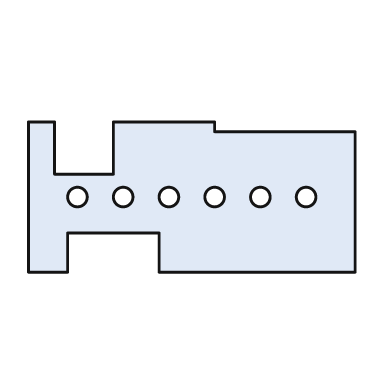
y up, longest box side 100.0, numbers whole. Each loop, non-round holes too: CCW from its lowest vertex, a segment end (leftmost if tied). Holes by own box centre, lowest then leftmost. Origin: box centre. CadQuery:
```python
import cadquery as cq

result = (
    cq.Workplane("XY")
    .moveTo(-50.0, -23.0)
    .lineTo(-38.0, -23.0)
    .lineTo(-38.0, -11.0)
    .lineTo(-10.0, -11.0)
    .lineTo(-10.0, -23.0)
    .lineTo(50.0, -23.0)
    .lineTo(50.0, 20.0)
    .lineTo(7.0, 20.0)
    .lineTo(7.0, 23.0)
    .lineTo(-24.0, 23.0)
    .lineTo(-24.0, 7.0)
    .lineTo(-42.0, 7.0)
    .lineTo(-42.0, 23.0)
    .lineTo(-50.0, 23.0)
    .close()
    .moveTo(-35.0, 0.0)
    .circle(3.0)
    .moveTo(-21.0, 0.0)
    .circle(3.0)
    .moveTo(-7.0, 0.0)
    .circle(3.0)
    .moveTo(7.0, 0.0)
    .circle(3.0)
    .moveTo(21.0, 0.0)
    .circle(3.0)
    .moveTo(35.0, 0.0)
    .circle(3.0)
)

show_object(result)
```